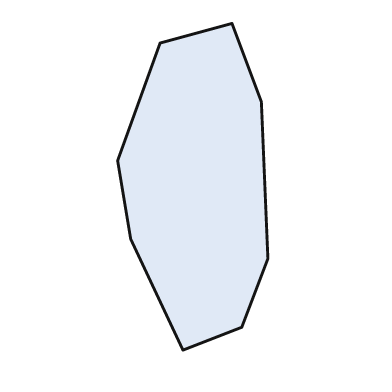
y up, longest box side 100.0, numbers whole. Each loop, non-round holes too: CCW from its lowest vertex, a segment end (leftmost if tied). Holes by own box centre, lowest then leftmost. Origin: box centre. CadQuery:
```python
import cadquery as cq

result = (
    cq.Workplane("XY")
    .moveTo(-3.0, -50.0)
    .lineTo(15.0, -43.0)
    .lineTo(23.0, -22.0)
    .lineTo(21.0, 26.0)
    .lineTo(12.0, 50.0)
    .lineTo(-10.0, 44.0)
    .lineTo(-23.0, 8.0)
    .lineTo(-19.0, -16.0)
    .close()
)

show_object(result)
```